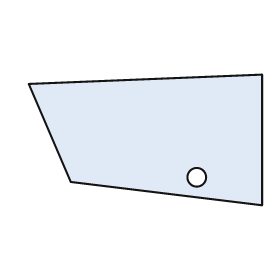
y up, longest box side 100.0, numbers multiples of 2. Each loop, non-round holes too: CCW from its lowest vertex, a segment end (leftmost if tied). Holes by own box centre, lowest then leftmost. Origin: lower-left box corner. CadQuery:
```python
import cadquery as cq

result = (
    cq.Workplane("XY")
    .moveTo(100.0, 0.0)
    .lineTo(100.0, 56.0)
    .lineTo(0.0, 52.0)
    .lineTo(18.0, 10.0)
    .close()
    .moveTo(72.0, 12.0)
    .circle(4.0)
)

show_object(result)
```